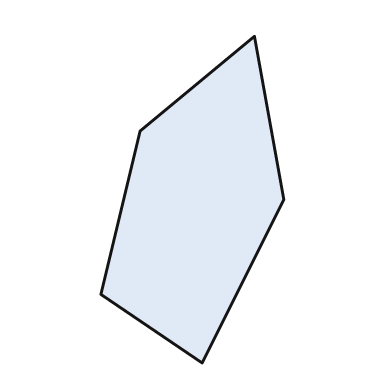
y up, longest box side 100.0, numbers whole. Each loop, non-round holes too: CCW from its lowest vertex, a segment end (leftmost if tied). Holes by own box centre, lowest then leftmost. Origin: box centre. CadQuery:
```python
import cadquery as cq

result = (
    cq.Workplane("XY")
    .moveTo(3.0, -50.0)
    .lineTo(28.0, 0.0)
    .lineTo(19.0, 50.0)
    .lineTo(-16.0, 21.0)
    .lineTo(-28.0, -29.0)
    .close()
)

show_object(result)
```